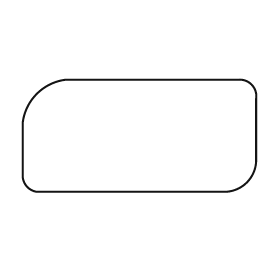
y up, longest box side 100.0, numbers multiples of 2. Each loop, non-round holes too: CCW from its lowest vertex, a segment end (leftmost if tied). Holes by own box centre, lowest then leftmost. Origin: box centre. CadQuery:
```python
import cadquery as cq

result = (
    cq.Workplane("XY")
    .moveTo(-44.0, -24.0)
    .lineTo(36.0, -24.0)
    .threePointArc((46.0, -20.0), (50.0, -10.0))
    .lineTo(50.0, 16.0)
    .threePointArc((48.0, 22.0), (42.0, 24.0))
    .lineTo(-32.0, 24.0)
    .threePointArc((-44.0, 18.0), (-50.0, 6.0))
    .lineTo(-50.0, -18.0)
    .threePointArc((-48.0, -22.0), (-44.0, -24.0))
    .close()
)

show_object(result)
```